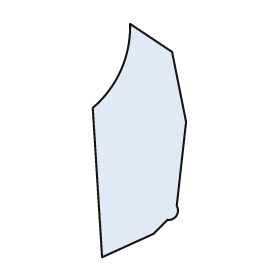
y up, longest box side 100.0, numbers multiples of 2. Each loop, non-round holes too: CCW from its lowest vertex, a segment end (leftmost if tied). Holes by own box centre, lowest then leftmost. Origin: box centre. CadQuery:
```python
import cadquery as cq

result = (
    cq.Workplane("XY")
    .moveTo(-16.0, -50.0)
    .lineTo(6.0, -40.0)
    .lineTo(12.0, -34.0)
    .threePointArc((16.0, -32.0), (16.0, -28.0))
    .lineTo(20.0, 8.0)
    .lineTo(14.0, 38.0)
    .lineTo(-4.0, 50.0)
    .threePointArc((-8.0, 30.0), (-20.0, 14.0))
    .close()
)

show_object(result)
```